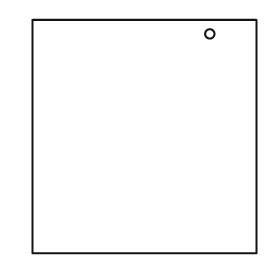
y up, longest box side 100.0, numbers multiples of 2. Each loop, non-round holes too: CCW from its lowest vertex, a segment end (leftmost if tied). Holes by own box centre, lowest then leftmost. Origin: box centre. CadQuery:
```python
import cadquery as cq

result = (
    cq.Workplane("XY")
    .moveTo(-48.0, -50.0)
    .lineTo(48.0, -50.0)
    .lineTo(48.0, 50.0)
    .lineTo(-48.0, 50.0)
    .close()
    .moveTo(28.0, 44.0)
    .circle(2.0)
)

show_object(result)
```